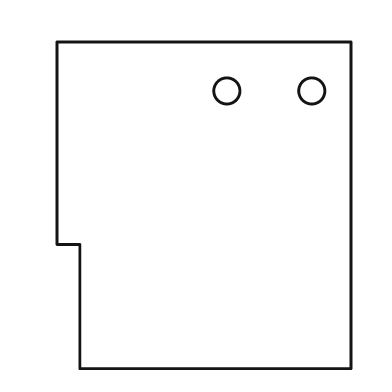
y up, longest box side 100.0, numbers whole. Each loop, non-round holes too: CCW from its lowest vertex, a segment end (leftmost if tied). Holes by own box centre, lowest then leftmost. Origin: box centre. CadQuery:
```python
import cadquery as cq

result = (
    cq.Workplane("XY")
    .moveTo(-38.0, -50.0)
    .lineTo(45.0, -50.0)
    .lineTo(45.0, 50.0)
    .lineTo(-45.0, 50.0)
    .lineTo(-45.0, -12.0)
    .lineTo(-38.0, -12.0)
    .close()
    .moveTo(7.0, 35.0)
    .circle(4.0)
    .moveTo(33.0, 35.0)
    .circle(4.0)
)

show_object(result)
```